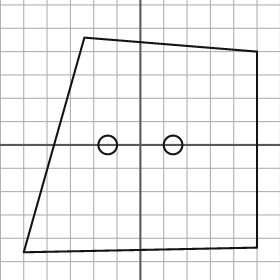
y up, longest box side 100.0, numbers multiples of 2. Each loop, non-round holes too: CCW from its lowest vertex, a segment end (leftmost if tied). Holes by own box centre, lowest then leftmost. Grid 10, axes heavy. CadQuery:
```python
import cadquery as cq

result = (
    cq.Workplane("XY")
    .moveTo(-50.0, -46.0)
    .lineTo(50.0, -44.0)
    .lineTo(50.0, 40.0)
    .lineTo(-24.0, 46.0)
    .close()
    .moveTo(-14.0, 0.0)
    .circle(4.0)
    .moveTo(14.0, 0.0)
    .circle(4.0)
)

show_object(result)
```